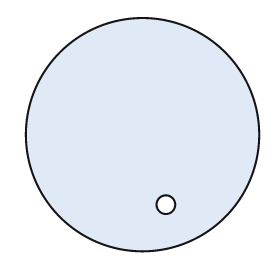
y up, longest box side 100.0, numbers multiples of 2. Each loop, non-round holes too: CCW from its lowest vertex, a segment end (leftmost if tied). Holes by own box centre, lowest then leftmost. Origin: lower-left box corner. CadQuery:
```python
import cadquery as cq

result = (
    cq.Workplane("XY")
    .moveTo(50.0, 50.0)
    .circle(50.0)
    .moveTo(60.0, 20.0)
    .circle(4.0)
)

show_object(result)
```